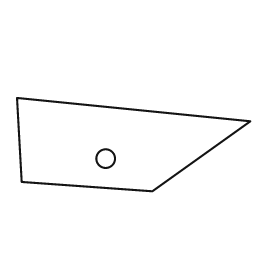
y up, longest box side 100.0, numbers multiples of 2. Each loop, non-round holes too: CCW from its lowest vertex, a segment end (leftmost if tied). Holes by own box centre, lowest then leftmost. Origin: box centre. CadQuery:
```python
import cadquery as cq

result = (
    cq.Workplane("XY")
    .moveTo(8.0, -20.0)
    .lineTo(50.0, 10.0)
    .lineTo(-50.0, 20.0)
    .lineTo(-48.0, -16.0)
    .close()
    .moveTo(-12.0, -6.0)
    .circle(4.0)
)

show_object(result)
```